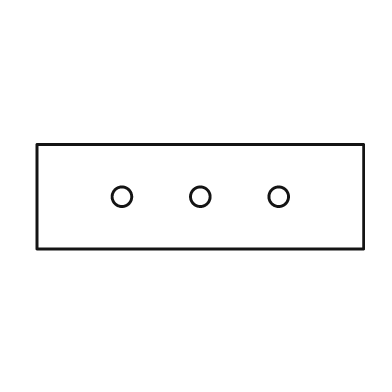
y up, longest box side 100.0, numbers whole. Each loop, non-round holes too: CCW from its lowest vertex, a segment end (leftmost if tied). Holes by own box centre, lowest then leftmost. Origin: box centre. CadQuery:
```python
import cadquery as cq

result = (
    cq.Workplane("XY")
    .moveTo(-50.0, -16.0)
    .lineTo(50.0, -16.0)
    .lineTo(50.0, 16.0)
    .lineTo(-50.0, 16.0)
    .close()
    .moveTo(-24.0, 0.0)
    .circle(3.0)
    .moveTo(0.0, 0.0)
    .circle(3.0)
    .moveTo(24.0, 0.0)
    .circle(3.0)
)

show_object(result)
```